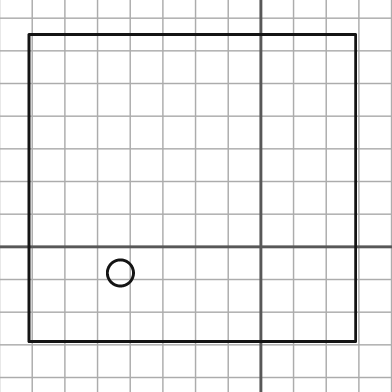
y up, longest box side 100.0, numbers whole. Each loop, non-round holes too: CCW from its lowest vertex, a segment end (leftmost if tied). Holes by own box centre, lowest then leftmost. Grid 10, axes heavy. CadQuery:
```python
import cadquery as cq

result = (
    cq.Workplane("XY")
    .moveTo(-71.0, -29.0)
    .lineTo(29.0, -29.0)
    .lineTo(29.0, 65.0)
    .lineTo(-71.0, 65.0)
    .close()
    .moveTo(-43.0, -8.0)
    .circle(4.0)
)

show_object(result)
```